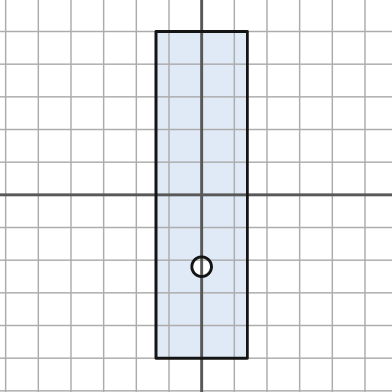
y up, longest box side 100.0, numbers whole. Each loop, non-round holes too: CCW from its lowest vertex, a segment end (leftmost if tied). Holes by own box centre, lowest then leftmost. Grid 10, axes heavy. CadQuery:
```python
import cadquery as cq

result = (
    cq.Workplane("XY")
    .moveTo(-14.0, -50.0)
    .lineTo(14.0, -50.0)
    .lineTo(14.0, 50.0)
    .lineTo(-14.0, 50.0)
    .close()
    .moveTo(0.0, -22.0)
    .circle(3.0)
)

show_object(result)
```